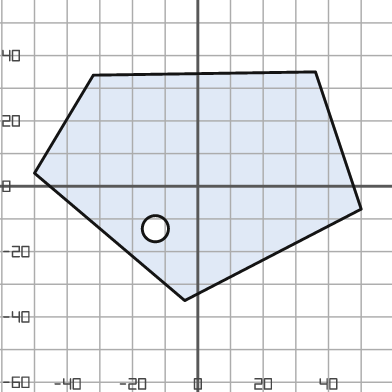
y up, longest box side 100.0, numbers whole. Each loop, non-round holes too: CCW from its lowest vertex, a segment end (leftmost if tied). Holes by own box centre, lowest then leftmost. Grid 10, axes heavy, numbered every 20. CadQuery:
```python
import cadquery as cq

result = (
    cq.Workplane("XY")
    .moveTo(-4.0, -35.0)
    .lineTo(50.0, -7.0)
    .lineTo(36.0, 35.0)
    .lineTo(-32.0, 34.0)
    .lineTo(-50.0, 4.0)
    .close()
    .moveTo(-13.0, -13.0)
    .circle(4.0)
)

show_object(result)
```